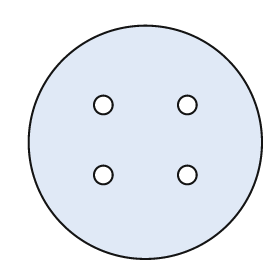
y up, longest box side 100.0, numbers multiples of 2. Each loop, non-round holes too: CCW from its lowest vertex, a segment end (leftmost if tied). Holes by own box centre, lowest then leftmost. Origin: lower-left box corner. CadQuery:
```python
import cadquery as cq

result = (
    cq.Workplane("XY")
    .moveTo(50.0, 50.0)
    .circle(50.0)
    .moveTo(32.0, 36.0)
    .circle(4.0)
    .moveTo(68.0, 36.0)
    .circle(4.0)
    .moveTo(32.0, 66.0)
    .circle(4.0)
    .moveTo(68.0, 66.0)
    .circle(4.0)
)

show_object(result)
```